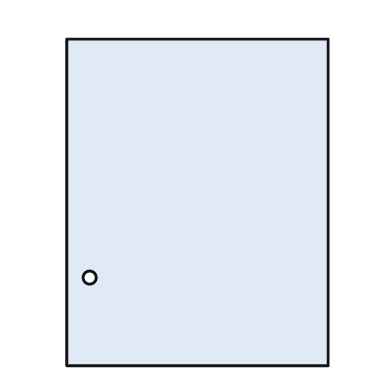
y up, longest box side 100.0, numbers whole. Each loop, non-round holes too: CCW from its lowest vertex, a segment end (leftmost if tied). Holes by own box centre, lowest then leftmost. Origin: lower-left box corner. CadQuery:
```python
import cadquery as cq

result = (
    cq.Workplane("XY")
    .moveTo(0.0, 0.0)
    .lineTo(80.0, 0.0)
    .lineTo(80.0, 100.0)
    .lineTo(0.0, 100.0)
    .close()
    .moveTo(7.0, 27.0)
    .circle(2.0)
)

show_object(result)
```